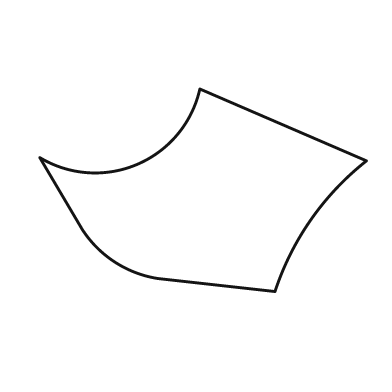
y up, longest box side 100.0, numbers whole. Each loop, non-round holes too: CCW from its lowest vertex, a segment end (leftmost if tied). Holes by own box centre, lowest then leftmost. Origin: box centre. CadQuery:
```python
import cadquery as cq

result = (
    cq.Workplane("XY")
    .moveTo(22.0, -31.0)
    .threePointArc((33.0, -9.0), (50.0, 9.0))
    .lineTo(-1.0, 31.0)
    .threePointArc((-20.0, 8.0), (-50.0, 10.0))
    .lineTo(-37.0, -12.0)
    .threePointArc((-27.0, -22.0), (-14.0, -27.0))
    .close()
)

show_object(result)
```